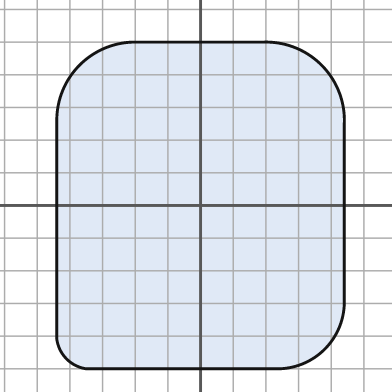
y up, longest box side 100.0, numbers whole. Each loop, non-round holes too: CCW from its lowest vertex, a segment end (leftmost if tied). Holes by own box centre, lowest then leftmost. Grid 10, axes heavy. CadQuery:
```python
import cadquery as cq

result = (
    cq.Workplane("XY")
    .moveTo(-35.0, -50.0)
    .lineTo(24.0, -50.0)
    .threePointArc((38.0, -44.0), (44.0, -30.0))
    .lineTo(44.0, 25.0)
    .threePointArc((37.0, 43.0), (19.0, 50.0))
    .lineTo(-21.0, 50.0)
    .threePointArc((-37.0, 43.0), (-44.0, 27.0))
    .lineTo(-44.0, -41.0)
    .threePointArc((-41.0, -47.0), (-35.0, -50.0))
    .close()
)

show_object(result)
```